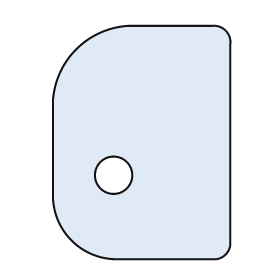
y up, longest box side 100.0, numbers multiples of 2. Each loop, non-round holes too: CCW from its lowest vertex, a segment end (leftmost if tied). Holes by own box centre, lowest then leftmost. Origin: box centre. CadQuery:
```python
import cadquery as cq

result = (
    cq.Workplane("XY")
    .moveTo(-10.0, -50.0)
    .lineTo(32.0, -50.0)
    .threePointArc((36.0, -48.0), (38.0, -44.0))
    .lineTo(38.0, 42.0)
    .threePointArc((36.0, 48.0), (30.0, 50.0))
    .lineTo(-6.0, 50.0)
    .threePointArc((-28.0, 40.0), (-38.0, 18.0))
    .lineTo(-38.0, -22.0)
    .threePointArc((-30.0, -42.0), (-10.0, -50.0))
    .close()
    .moveTo(-12.0, -14.0)
    .circle(8.0)
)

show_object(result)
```